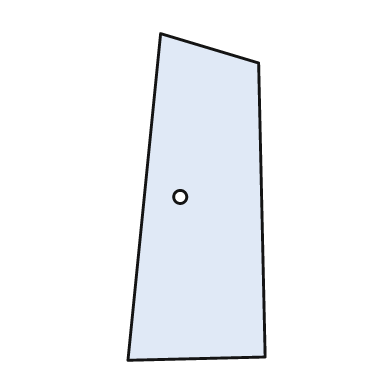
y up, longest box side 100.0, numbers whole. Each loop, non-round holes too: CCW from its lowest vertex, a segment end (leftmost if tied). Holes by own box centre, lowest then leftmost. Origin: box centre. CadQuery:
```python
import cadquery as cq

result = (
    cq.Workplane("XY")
    .moveTo(-21.0, -50.0)
    .lineTo(21.0, -49.0)
    .lineTo(19.0, 41.0)
    .lineTo(-11.0, 50.0)
    .close()
    .moveTo(-5.0, 0.0)
    .circle(2.0)
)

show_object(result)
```